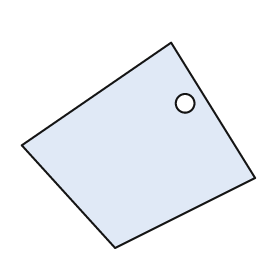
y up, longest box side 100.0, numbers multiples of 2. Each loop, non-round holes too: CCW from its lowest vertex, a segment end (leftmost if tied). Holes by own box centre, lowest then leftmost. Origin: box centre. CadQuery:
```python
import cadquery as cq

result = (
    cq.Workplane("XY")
    .moveTo(-10.0, -44.0)
    .lineTo(50.0, -14.0)
    .lineTo(14.0, 44.0)
    .lineTo(-50.0, 0.0)
    .close()
    .moveTo(20.0, 18.0)
    .circle(4.0)
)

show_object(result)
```